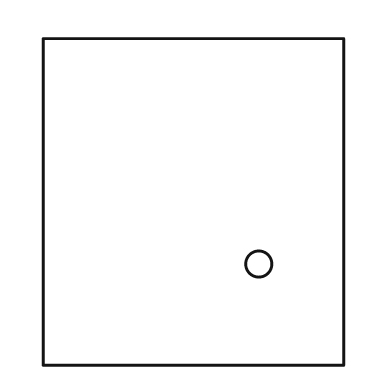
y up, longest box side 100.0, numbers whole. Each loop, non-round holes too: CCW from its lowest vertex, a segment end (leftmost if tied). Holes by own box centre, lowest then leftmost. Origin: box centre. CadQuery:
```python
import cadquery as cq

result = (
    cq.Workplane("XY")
    .moveTo(-46.0, -50.0)
    .lineTo(46.0, -50.0)
    .lineTo(46.0, 50.0)
    .lineTo(-46.0, 50.0)
    .close()
    .moveTo(20.0, -19.0)
    .circle(4.0)
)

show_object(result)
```